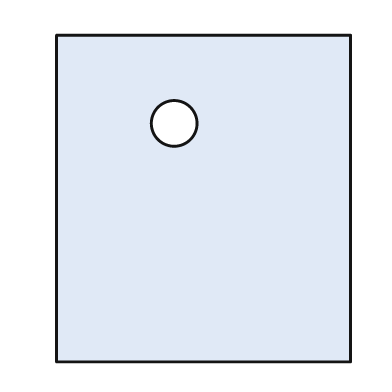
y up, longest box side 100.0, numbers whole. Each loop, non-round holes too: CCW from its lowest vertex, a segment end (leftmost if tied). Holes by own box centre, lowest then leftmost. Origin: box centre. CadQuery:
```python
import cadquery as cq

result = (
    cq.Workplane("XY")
    .moveTo(-45.0, -50.0)
    .lineTo(45.0, -50.0)
    .lineTo(45.0, 50.0)
    .lineTo(-45.0, 50.0)
    .close()
    .moveTo(-9.0, 23.0)
    .circle(7.0)
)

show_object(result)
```